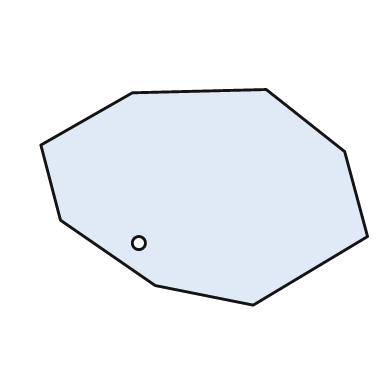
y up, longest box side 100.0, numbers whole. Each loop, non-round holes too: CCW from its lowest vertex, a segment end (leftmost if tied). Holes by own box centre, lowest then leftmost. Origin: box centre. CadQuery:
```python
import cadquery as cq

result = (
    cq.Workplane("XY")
    .moveTo(15.0, -33.0)
    .lineTo(50.0, -12.0)
    .lineTo(43.0, 14.0)
    .lineTo(19.0, 33.0)
    .lineTo(-22.0, 32.0)
    .lineTo(-50.0, 16.0)
    .lineTo(-44.0, -7.0)
    .lineTo(-15.0, -27.0)
    .close()
    .moveTo(-20.0, -14.0)
    .circle(2.0)
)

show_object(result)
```